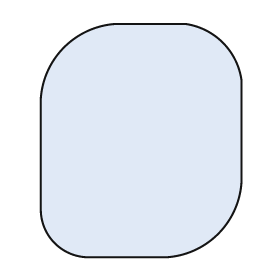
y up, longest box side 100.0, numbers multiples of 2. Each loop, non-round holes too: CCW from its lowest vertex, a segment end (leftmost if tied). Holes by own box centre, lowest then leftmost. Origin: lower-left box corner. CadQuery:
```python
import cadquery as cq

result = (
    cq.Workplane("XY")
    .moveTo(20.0, 0.0)
    .lineTo(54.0, 0.0)
    .threePointArc((76.0, 10.0), (86.0, 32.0))
    .lineTo(86.0, 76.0)
    .threePointArc((78.0, 92.0), (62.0, 100.0))
    .lineTo(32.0, 100.0)
    .threePointArc((10.0, 90.0), (0.0, 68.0))
    .lineTo(0.0, 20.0)
    .threePointArc((6.0, 6.0), (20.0, 0.0))
    .close()
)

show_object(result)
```